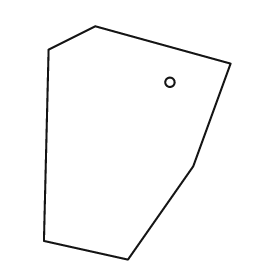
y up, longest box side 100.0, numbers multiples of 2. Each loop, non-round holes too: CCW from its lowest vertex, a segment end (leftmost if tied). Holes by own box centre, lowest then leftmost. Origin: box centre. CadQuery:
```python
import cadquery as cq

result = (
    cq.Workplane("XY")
    .moveTo(-4.0, -50.0)
    .lineTo(24.0, -10.0)
    .lineTo(40.0, 34.0)
    .lineTo(-18.0, 50.0)
    .lineTo(-38.0, 40.0)
    .lineTo(-40.0, -42.0)
    .close()
    .moveTo(14.0, 26.0)
    .circle(2.0)
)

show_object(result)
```